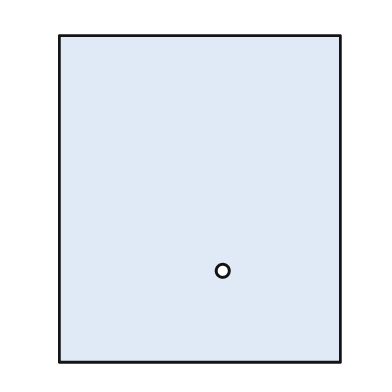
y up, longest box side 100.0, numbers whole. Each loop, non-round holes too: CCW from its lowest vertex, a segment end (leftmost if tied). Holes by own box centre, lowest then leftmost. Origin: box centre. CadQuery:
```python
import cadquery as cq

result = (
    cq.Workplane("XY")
    .moveTo(-43.0, -50.0)
    .lineTo(43.0, -50.0)
    .lineTo(43.0, 50.0)
    .lineTo(-43.0, 50.0)
    .close()
    .moveTo(7.0, -22.0)
    .circle(2.0)
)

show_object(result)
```